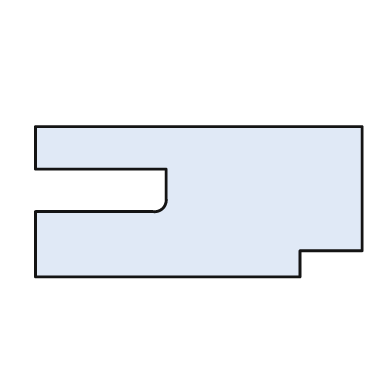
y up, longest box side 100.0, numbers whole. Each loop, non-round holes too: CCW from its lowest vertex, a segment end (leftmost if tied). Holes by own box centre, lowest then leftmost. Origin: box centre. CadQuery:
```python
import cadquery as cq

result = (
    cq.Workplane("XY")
    .moveTo(-50.0, -23.0)
    .lineTo(31.0, -23.0)
    .lineTo(31.0, -15.0)
    .lineTo(50.0, -15.0)
    .lineTo(50.0, 23.0)
    .lineTo(-50.0, 23.0)
    .lineTo(-50.0, 10.0)
    .lineTo(-10.0, 10.0)
    .lineTo(-10.0, 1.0)
    .threePointArc((-11.0, -2.0), (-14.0, -3.0))
    .lineTo(-50.0, -3.0)
    .close()
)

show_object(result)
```